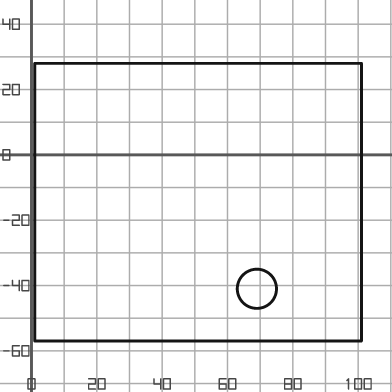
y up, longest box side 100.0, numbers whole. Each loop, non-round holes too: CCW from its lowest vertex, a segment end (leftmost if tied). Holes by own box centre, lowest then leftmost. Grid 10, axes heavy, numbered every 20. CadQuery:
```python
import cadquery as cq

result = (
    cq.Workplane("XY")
    .moveTo(1.0, -57.0)
    .lineTo(101.0, -57.0)
    .lineTo(101.0, 28.0)
    .lineTo(1.0, 28.0)
    .close()
    .moveTo(69.0, -41.0)
    .circle(6.0)
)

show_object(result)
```